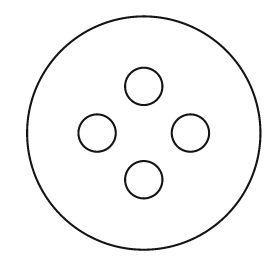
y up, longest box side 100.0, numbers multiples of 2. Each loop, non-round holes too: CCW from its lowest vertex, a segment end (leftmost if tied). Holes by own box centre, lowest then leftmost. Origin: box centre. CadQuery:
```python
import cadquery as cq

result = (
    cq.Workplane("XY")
    .moveTo(0.0, 0.0)
    .circle(50.0)
    .moveTo(0.0, -20.0)
    .circle(8.0)
    .moveTo(-20.0, 0.0)
    .circle(8.0)
    .moveTo(20.0, 0.0)
    .circle(8.0)
    .moveTo(0.0, 20.0)
    .circle(8.0)
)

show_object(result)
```